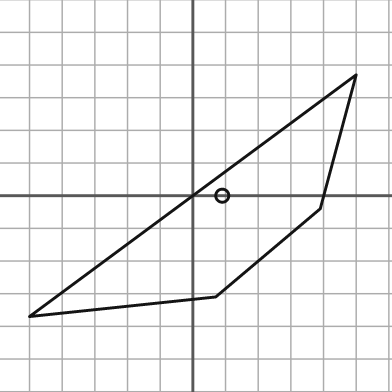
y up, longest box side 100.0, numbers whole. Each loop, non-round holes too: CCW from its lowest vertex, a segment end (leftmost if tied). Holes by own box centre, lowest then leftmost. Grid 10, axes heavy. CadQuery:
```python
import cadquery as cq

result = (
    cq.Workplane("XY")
    .moveTo(-50.0, -37.0)
    .lineTo(7.0, -31.0)
    .lineTo(39.0, -4.0)
    .lineTo(50.0, 37.0)
    .close()
    .moveTo(9.0, 0.0)
    .circle(2.0)
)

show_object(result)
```